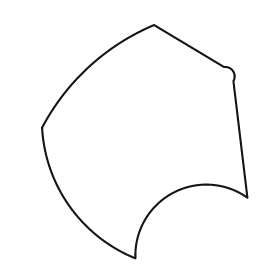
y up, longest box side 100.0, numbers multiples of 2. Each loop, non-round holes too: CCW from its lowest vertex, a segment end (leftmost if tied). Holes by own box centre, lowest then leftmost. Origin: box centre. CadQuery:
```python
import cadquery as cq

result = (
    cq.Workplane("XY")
    .moveTo(-4.0, -50.0)
    .threePointArc((12.0, -22.0), (44.0, -24.0))
    .lineTo(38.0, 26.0)
    .threePointArc((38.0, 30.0), (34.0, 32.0))
    .lineTo(4.0, 50.0)
    .threePointArc((-24.0, 32.0), (-44.0, 6.0))
    .threePointArc((-32.0, -28.0), (-4.0, -50.0))
    .close()
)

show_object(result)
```